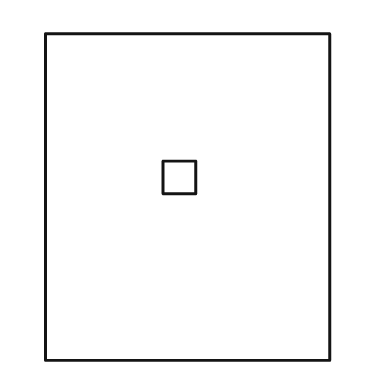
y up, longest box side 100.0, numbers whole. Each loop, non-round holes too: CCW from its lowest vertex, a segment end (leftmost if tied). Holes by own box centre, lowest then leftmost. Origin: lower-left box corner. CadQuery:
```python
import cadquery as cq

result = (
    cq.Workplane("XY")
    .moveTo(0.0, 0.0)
    .lineTo(87.0, 0.0)
    .lineTo(87.0, 100.0)
    .lineTo(0.0, 100.0)
    .close()
    .moveTo(36.0, 51.0)
    .lineTo(46.0, 51.0)
    .lineTo(46.0, 61.0)
    .lineTo(36.0, 61.0)
    .close()
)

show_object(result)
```